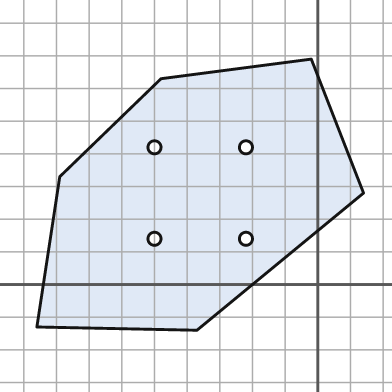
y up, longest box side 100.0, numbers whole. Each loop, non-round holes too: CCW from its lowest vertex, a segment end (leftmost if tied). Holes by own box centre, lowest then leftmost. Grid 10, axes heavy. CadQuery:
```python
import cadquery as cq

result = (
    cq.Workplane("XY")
    .moveTo(-37.0, -14.0)
    .lineTo(14.0, 28.0)
    .lineTo(-2.0, 69.0)
    .lineTo(-48.0, 63.0)
    .lineTo(-79.0, 33.0)
    .lineTo(-86.0, -13.0)
    .close()
    .moveTo(-50.0, 14.0)
    .circle(2.0)
    .moveTo(-22.0, 14.0)
    .circle(2.0)
    .moveTo(-50.0, 42.0)
    .circle(2.0)
    .moveTo(-22.0, 42.0)
    .circle(2.0)
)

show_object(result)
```